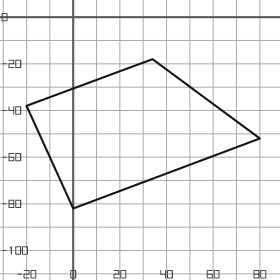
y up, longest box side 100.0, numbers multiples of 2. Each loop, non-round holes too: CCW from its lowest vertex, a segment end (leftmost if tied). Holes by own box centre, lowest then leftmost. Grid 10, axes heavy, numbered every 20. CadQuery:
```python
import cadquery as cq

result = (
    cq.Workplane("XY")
    .moveTo(0.0, -82.0)
    .lineTo(80.0, -52.0)
    .lineTo(34.0, -18.0)
    .lineTo(-20.0, -38.0)
    .close()
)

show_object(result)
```